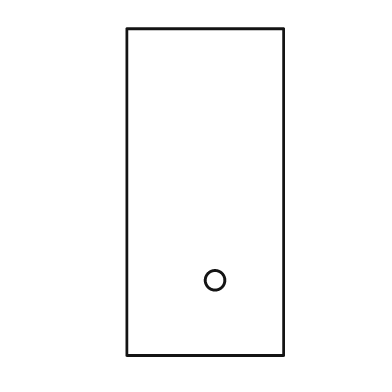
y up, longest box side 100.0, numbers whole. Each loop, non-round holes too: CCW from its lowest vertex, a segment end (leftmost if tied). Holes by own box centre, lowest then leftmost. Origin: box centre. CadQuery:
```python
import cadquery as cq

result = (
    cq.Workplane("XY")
    .moveTo(-24.0, -50.0)
    .lineTo(24.0, -50.0)
    .lineTo(24.0, 50.0)
    .lineTo(-24.0, 50.0)
    .close()
    .moveTo(3.0, -27.0)
    .circle(3.0)
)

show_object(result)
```